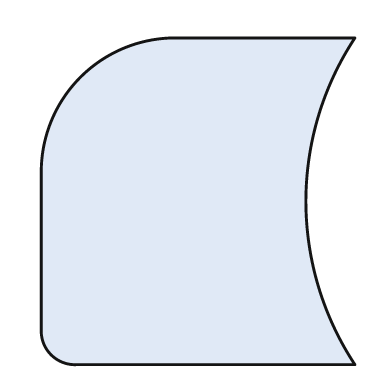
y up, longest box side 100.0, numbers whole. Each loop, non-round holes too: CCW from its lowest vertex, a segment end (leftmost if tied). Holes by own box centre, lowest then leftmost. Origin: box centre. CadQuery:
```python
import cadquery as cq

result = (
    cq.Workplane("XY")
    .moveTo(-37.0, -50.0)
    .lineTo(48.0, -50.0)
    .threePointArc((33.0, 0.0), (48.0, 50.0))
    .lineTo(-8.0, 50.0)
    .threePointArc((-36.0, 38.0), (-48.0, 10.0))
    .lineTo(-48.0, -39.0)
    .threePointArc((-45.0, -47.0), (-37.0, -50.0))
    .close()
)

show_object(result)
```